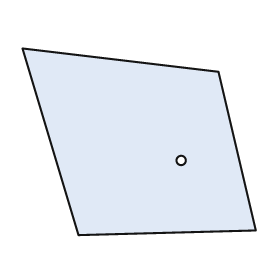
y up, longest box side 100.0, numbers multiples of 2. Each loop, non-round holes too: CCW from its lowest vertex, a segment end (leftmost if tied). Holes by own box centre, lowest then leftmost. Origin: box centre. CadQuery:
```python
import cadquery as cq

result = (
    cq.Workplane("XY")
    .moveTo(-26.0, -40.0)
    .lineTo(50.0, -38.0)
    .lineTo(34.0, 30.0)
    .lineTo(-50.0, 40.0)
    .close()
    .moveTo(18.0, -8.0)
    .circle(2.0)
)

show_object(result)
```